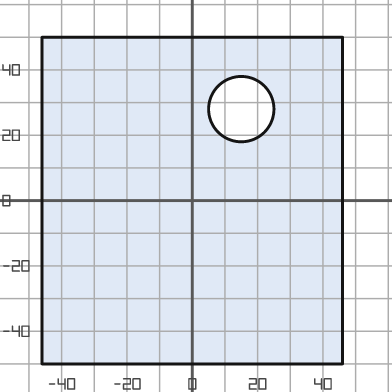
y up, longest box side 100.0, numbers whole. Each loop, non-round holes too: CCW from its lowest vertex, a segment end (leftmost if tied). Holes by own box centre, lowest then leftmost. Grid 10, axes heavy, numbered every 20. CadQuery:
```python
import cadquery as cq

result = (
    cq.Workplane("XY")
    .moveTo(-46.0, -50.0)
    .lineTo(46.0, -50.0)
    .lineTo(46.0, 50.0)
    .lineTo(-46.0, 50.0)
    .close()
    .moveTo(15.0, 28.0)
    .circle(10.0)
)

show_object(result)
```